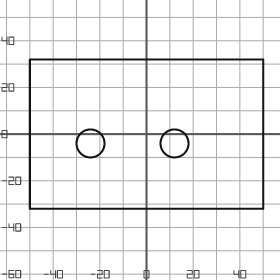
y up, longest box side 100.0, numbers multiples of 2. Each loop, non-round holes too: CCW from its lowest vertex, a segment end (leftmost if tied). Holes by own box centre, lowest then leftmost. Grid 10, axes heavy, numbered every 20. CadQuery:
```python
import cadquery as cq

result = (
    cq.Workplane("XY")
    .moveTo(-50.0, -32.0)
    .lineTo(50.0, -32.0)
    .lineTo(50.0, 32.0)
    .lineTo(-50.0, 32.0)
    .close()
    .moveTo(-24.0, -4.0)
    .circle(6.0)
    .moveTo(12.0, -4.0)
    .circle(6.0)
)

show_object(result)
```